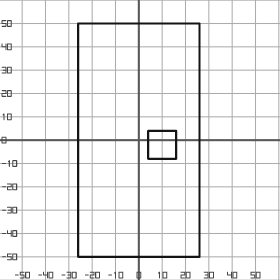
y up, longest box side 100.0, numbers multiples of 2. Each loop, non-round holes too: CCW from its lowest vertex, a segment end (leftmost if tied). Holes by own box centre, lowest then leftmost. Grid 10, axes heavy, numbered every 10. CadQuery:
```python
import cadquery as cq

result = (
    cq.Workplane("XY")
    .moveTo(-26.0, -50.0)
    .lineTo(26.0, -50.0)
    .lineTo(26.0, 50.0)
    .lineTo(-26.0, 50.0)
    .close()
    .moveTo(4.0, -8.0)
    .lineTo(16.0, -8.0)
    .lineTo(16.0, 4.0)
    .lineTo(4.0, 4.0)
    .close()
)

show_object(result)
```